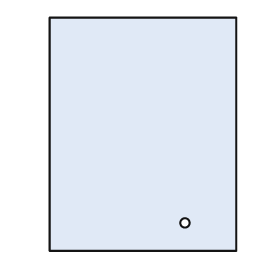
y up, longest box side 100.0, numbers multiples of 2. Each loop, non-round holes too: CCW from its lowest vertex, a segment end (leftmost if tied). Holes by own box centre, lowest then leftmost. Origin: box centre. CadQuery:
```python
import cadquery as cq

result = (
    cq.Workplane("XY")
    .moveTo(-40.0, -50.0)
    .lineTo(40.0, -50.0)
    .lineTo(40.0, 50.0)
    .lineTo(-40.0, 50.0)
    .close()
    .moveTo(18.0, -38.0)
    .circle(2.0)
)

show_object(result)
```